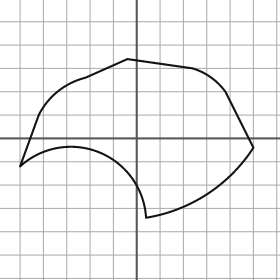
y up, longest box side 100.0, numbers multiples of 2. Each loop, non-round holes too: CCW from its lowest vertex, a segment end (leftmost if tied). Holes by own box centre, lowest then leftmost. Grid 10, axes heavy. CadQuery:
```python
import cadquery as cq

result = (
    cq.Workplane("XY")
    .moveTo(4.0, -34.0)
    .threePointArc((30.0, -24.0), (50.0, -4.0))
    .lineTo(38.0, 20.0)
    .threePointArc((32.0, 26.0), (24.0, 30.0))
    .lineTo(-4.0, 34.0)
    .lineTo(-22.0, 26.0)
    .threePointArc((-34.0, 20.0), (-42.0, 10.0))
    .lineTo(-50.0, -12.0)
    .threePointArc((-16.0, -6.0), (4.0, -34.0))
    .close()
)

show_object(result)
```